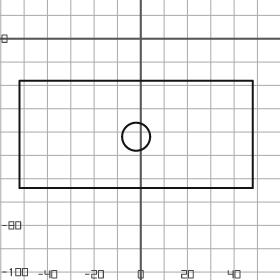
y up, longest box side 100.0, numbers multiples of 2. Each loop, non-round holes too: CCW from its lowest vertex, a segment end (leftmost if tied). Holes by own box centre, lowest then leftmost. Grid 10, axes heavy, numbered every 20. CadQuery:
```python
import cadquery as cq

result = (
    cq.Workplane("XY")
    .moveTo(-52.0, -64.0)
    .lineTo(48.0, -64.0)
    .lineTo(48.0, -18.0)
    .lineTo(-52.0, -18.0)
    .close()
    .moveTo(-2.0, -42.0)
    .circle(6.0)
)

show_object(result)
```